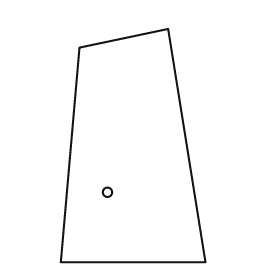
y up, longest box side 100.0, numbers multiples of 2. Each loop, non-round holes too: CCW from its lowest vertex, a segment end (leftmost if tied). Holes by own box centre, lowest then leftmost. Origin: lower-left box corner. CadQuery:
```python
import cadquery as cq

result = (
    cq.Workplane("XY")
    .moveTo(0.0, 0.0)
    .lineTo(62.0, 0.0)
    .lineTo(46.0, 100.0)
    .lineTo(8.0, 92.0)
    .close()
    .moveTo(20.0, 30.0)
    .circle(2.0)
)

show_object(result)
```